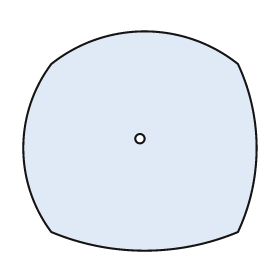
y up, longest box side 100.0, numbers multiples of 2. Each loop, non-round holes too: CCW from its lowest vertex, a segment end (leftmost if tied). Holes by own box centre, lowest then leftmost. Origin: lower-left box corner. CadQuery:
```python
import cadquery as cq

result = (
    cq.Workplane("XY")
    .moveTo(12.0, 8.0)
    .threePointArc((52.0, 0.0), (92.0, 8.0))
    .threePointArc((100.0, 44.0), (92.0, 80.0))
    .threePointArc((52.0, 94.0), (12.0, 80.0))
    .threePointArc((0.0, 44.0), (12.0, 8.0))
    .close()
    .moveTo(50.0, 48.0)
    .circle(2.0)
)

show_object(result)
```